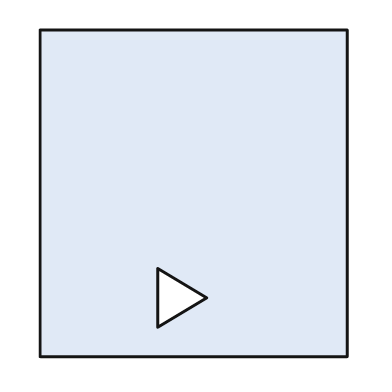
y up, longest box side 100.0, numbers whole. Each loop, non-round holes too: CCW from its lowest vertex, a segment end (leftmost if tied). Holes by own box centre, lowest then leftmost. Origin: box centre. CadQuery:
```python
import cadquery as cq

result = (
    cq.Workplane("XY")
    .moveTo(-47.0, -50.0)
    .lineTo(47.0, -50.0)
    .lineTo(47.0, 50.0)
    .lineTo(-47.0, 50.0)
    .close()
    .moveTo(-11.0, -41.0)
    .lineTo(4.0, -32.0)
    .lineTo(-11.0, -23.0)
    .close()
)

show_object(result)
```